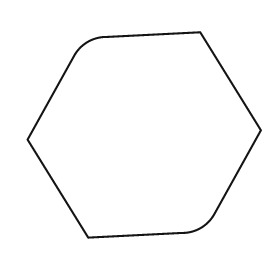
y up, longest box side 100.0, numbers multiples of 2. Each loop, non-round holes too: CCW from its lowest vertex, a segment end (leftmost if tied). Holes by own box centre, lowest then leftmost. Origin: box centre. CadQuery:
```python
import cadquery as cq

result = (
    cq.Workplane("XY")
    .moveTo(-24.0, -44.0)
    .lineTo(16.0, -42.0)
    .threePointArc((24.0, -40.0), (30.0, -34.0))
    .lineTo(50.0, 2.0)
    .lineTo(24.0, 44.0)
    .lineTo(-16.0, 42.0)
    .threePointArc((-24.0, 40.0), (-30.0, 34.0))
    .lineTo(-50.0, -2.0)
    .close()
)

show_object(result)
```